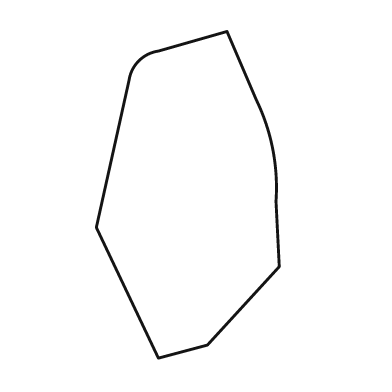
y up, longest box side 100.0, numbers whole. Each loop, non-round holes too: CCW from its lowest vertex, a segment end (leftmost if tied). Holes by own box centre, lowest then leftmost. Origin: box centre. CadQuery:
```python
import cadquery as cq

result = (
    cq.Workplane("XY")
    .moveTo(-9.0, -50.0)
    .lineTo(6.0, -46.0)
    .lineTo(28.0, -22.0)
    .lineTo(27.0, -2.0)
    .threePointArc((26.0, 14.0), (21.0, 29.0))
    .lineTo(12.0, 50.0)
    .lineTo(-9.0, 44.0)
    .threePointArc((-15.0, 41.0), (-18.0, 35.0))
    .lineTo(-28.0, -10.0)
    .close()
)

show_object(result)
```